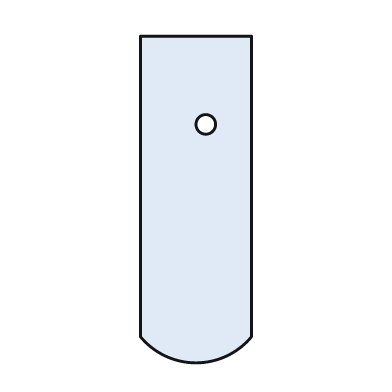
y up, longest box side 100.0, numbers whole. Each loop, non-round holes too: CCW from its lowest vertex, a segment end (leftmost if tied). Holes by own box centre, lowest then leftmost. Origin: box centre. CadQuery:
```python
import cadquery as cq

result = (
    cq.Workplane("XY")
    .moveTo(-17.0, -42.0)
    .threePointArc((0.0, -50.0), (17.0, -42.0))
    .lineTo(17.0, 50.0)
    .lineTo(-17.0, 50.0)
    .close()
    .moveTo(3.0, 23.0)
    .circle(3.0)
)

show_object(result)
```